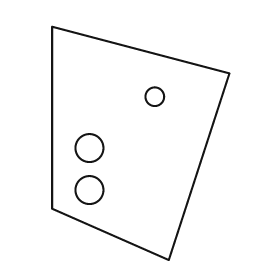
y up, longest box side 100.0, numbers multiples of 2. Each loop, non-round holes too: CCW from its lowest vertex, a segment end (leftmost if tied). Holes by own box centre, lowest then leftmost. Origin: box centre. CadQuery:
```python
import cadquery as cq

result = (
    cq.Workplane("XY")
    .moveTo(12.0, -50.0)
    .lineTo(38.0, 30.0)
    .lineTo(-38.0, 50.0)
    .lineTo(-38.0, -28.0)
    .close()
    .moveTo(-22.0, -20.0)
    .circle(6.0)
    .moveTo(-22.0, -2.0)
    .circle(6.0)
    .moveTo(6.0, 20.0)
    .circle(4.0)
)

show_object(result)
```